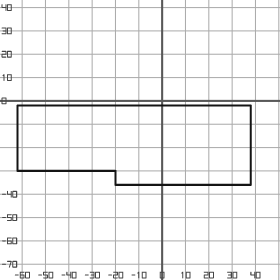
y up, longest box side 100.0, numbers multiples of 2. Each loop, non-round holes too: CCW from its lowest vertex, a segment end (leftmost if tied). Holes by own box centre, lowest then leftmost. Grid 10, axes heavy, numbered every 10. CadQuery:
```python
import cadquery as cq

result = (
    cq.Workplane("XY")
    .moveTo(-20.0, -36.0)
    .lineTo(38.0, -36.0)
    .lineTo(38.0, -2.0)
    .lineTo(-62.0, -2.0)
    .lineTo(-62.0, -30.0)
    .lineTo(-20.0, -30.0)
    .close()
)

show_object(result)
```